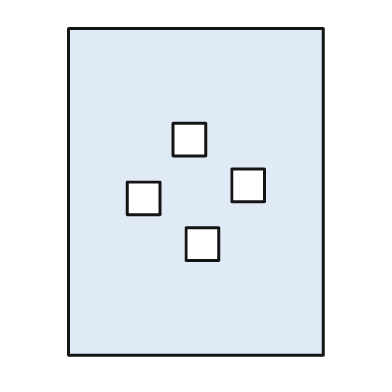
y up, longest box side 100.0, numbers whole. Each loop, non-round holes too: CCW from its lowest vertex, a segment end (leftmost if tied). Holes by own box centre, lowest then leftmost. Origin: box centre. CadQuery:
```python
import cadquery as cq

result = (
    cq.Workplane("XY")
    .moveTo(-39.0, -50.0)
    .lineTo(39.0, -50.0)
    .lineTo(39.0, 50.0)
    .lineTo(-39.0, 50.0)
    .close()
    .moveTo(-3.0, -21.0)
    .lineTo(7.0, -21.0)
    .lineTo(7.0, -11.0)
    .lineTo(-3.0, -11.0)
    .close()
    .moveTo(-21.0, -7.0)
    .lineTo(-11.0, -7.0)
    .lineTo(-11.0, 3.0)
    .lineTo(-21.0, 3.0)
    .close()
    .moveTo(11.0, -3.0)
    .lineTo(21.0, -3.0)
    .lineTo(21.0, 7.0)
    .lineTo(11.0, 7.0)
    .close()
    .moveTo(-7.0, 11.0)
    .lineTo(3.0, 11.0)
    .lineTo(3.0, 21.0)
    .lineTo(-7.0, 21.0)
    .close()
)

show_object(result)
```